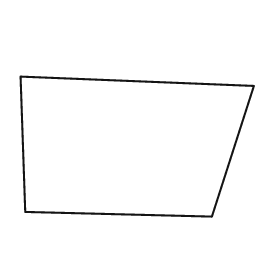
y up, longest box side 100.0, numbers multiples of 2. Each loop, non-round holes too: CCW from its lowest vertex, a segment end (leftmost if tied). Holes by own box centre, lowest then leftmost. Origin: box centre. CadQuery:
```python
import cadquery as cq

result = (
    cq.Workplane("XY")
    .moveTo(32.0, -30.0)
    .lineTo(50.0, 26.0)
    .lineTo(-50.0, 30.0)
    .lineTo(-48.0, -28.0)
    .close()
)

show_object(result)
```